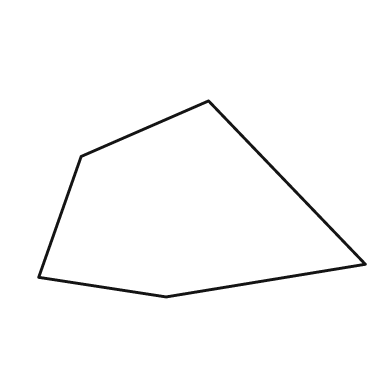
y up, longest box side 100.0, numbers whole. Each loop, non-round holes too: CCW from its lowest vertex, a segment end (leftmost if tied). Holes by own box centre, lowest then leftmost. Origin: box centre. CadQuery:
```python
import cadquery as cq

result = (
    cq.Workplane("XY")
    .moveTo(-11.0, -30.0)
    .lineTo(50.0, -20.0)
    .lineTo(2.0, 30.0)
    .lineTo(-37.0, 13.0)
    .lineTo(-50.0, -24.0)
    .close()
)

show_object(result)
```